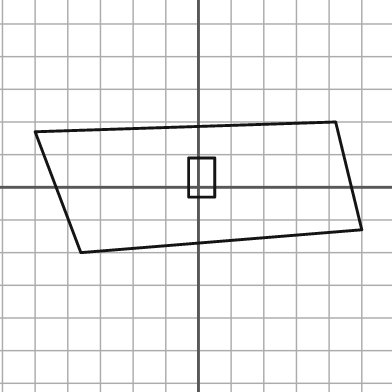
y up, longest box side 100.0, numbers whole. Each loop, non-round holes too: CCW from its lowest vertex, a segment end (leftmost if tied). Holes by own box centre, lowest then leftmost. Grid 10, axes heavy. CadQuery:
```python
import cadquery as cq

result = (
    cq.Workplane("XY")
    .moveTo(-36.0, -20.0)
    .lineTo(50.0, -13.0)
    .lineTo(42.0, 20.0)
    .lineTo(-50.0, 17.0)
    .close()
    .moveTo(-3.0, -3.0)
    .lineTo(5.0, -3.0)
    .lineTo(5.0, 9.0)
    .lineTo(-3.0, 9.0)
    .close()
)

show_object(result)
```